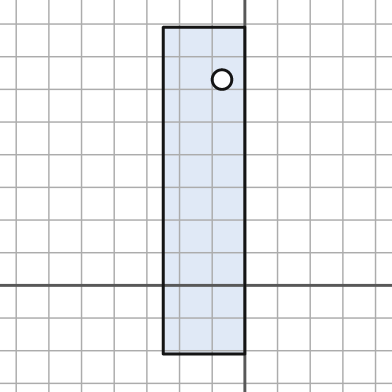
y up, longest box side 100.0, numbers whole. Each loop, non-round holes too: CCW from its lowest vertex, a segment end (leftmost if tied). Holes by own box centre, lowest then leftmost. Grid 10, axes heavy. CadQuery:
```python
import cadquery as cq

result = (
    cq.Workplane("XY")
    .moveTo(-25.0, -21.0)
    .lineTo(0.0, -21.0)
    .lineTo(0.0, 79.0)
    .lineTo(-25.0, 79.0)
    .close()
    .moveTo(-7.0, 63.0)
    .circle(3.0)
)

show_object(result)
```